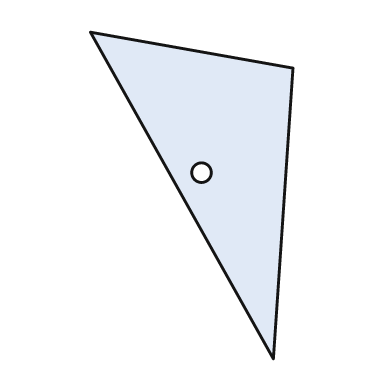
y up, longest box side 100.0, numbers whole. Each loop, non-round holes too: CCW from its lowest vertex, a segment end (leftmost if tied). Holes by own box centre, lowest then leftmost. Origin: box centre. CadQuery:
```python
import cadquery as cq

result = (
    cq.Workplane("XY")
    .moveTo(25.0, -50.0)
    .lineTo(31.0, 39.0)
    .lineTo(-31.0, 50.0)
    .close()
    .moveTo(3.0, 7.0)
    .circle(3.0)
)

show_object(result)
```